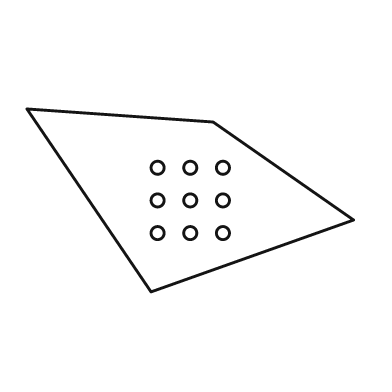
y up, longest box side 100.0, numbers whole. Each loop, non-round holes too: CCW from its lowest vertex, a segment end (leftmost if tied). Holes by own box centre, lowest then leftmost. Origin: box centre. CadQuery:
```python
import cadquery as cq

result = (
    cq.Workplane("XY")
    .moveTo(-12.0, -28.0)
    .lineTo(50.0, -6.0)
    .lineTo(7.0, 24.0)
    .lineTo(-50.0, 28.0)
    .close()
    .moveTo(-10.0, -10.0)
    .circle(2.0)
    .moveTo(0.0, -10.0)
    .circle(2.0)
    .moveTo(10.0, -10.0)
    .circle(2.0)
    .moveTo(-10.0, 0.0)
    .circle(2.0)
    .moveTo(0.0, 0.0)
    .circle(2.0)
    .moveTo(10.0, 0.0)
    .circle(2.0)
    .moveTo(-10.0, 10.0)
    .circle(2.0)
    .moveTo(0.0, 10.0)
    .circle(2.0)
    .moveTo(10.0, 10.0)
    .circle(2.0)
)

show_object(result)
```